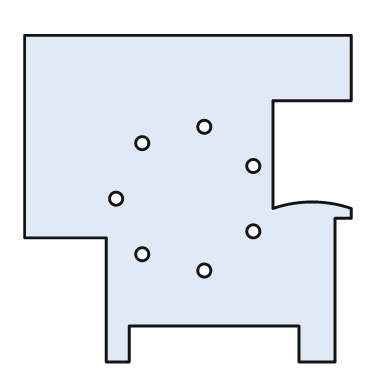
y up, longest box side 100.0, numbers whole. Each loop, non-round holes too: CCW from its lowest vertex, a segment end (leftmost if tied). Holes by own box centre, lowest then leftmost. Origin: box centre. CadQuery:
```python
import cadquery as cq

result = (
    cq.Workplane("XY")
    .moveTo(-25.0, -50.0)
    .lineTo(-18.0, -50.0)
    .lineTo(-18.0, -39.0)
    .lineTo(34.0, -39.0)
    .lineTo(34.0, -50.0)
    .lineTo(45.0, -50.0)
    .lineTo(45.0, -6.0)
    .lineTo(50.0, -6.0)
    .lineTo(50.0, -3.0)
    .threePointArc((38.0, -1.0), (26.0, -3.0))
    .lineTo(26.0, 30.0)
    .lineTo(50.0, 30.0)
    .lineTo(50.0, 50.0)
    .lineTo(-50.0, 50.0)
    .lineTo(-50.0, -12.0)
    .lineTo(-25.0, -12.0)
    .close()
    .moveTo(5.0, -22.0)
    .circle(2.0)
    .moveTo(-14.0, -17.0)
    .circle(2.0)
    .moveTo(20.0, -10.0)
    .circle(2.0)
    .moveTo(-22.0, 0.0)
    .circle(2.0)
    .moveTo(20.0, 10.0)
    .circle(2.0)
    .moveTo(-14.0, 17.0)
    .circle(2.0)
    .moveTo(5.0, 22.0)
    .circle(2.0)
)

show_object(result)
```